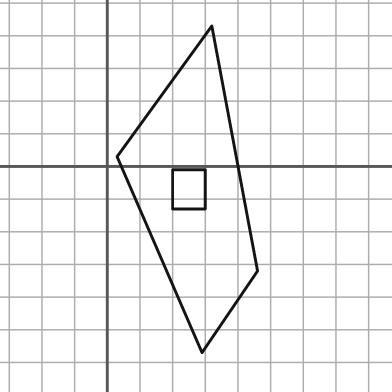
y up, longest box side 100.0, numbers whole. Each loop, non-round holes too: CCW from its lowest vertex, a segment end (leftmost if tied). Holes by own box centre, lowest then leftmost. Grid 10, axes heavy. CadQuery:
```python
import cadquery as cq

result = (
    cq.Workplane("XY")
    .moveTo(29.0, -57.0)
    .lineTo(46.0, -32.0)
    .lineTo(32.0, 43.0)
    .lineTo(3.0, 3.0)
    .close()
    .moveTo(20.0, -13.0)
    .lineTo(30.0, -13.0)
    .lineTo(30.0, -1.0)
    .lineTo(20.0, -1.0)
    .close()
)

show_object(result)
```